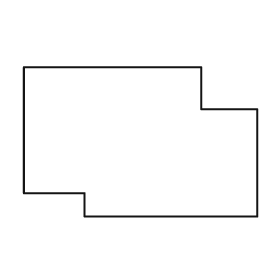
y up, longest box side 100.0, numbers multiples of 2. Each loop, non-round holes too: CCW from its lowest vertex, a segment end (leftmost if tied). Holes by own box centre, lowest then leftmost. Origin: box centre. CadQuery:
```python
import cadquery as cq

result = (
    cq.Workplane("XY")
    .moveTo(-24.0, -32.0)
    .lineTo(50.0, -32.0)
    .lineTo(50.0, 14.0)
    .lineTo(26.0, 14.0)
    .lineTo(26.0, 32.0)
    .lineTo(-50.0, 32.0)
    .lineTo(-50.0, -22.0)
    .lineTo(-24.0, -22.0)
    .close()
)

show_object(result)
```